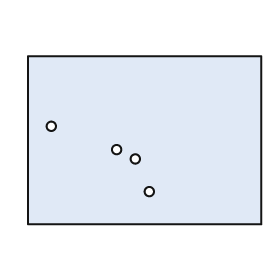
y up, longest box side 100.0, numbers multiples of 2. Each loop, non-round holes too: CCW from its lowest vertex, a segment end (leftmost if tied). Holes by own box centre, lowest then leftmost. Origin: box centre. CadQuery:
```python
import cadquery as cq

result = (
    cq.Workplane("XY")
    .moveTo(-50.0, -36.0)
    .lineTo(50.0, -36.0)
    .lineTo(50.0, 36.0)
    .lineTo(-50.0, 36.0)
    .close()
    .moveTo(2.0, -22.0)
    .circle(2.0)
    .moveTo(-4.0, -8.0)
    .circle(2.0)
    .moveTo(-12.0, -4.0)
    .circle(2.0)
    .moveTo(-40.0, 6.0)
    .circle(2.0)
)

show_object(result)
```